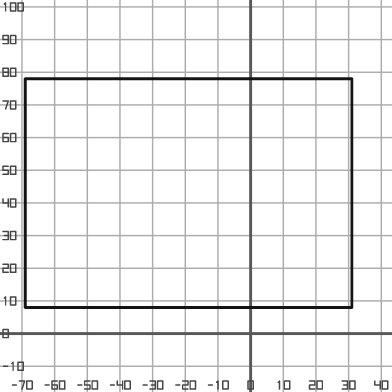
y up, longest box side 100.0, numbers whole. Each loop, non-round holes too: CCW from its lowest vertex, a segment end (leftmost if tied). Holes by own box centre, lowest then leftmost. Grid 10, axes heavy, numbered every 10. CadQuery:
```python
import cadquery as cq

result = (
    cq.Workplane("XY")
    .moveTo(-69.0, 8.0)
    .lineTo(31.0, 8.0)
    .lineTo(31.0, 78.0)
    .lineTo(-69.0, 78.0)
    .close()
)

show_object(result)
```